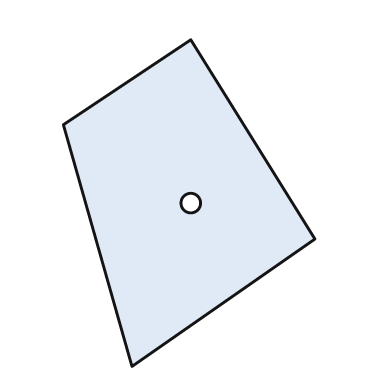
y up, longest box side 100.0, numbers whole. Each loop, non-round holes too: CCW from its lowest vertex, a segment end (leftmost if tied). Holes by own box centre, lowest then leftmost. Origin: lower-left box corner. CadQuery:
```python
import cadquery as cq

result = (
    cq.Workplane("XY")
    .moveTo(21.0, 0.0)
    .lineTo(77.0, 39.0)
    .lineTo(39.0, 100.0)
    .lineTo(0.0, 74.0)
    .close()
    .moveTo(39.0, 50.0)
    .circle(3.0)
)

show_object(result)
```